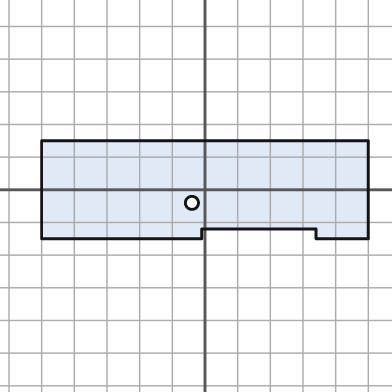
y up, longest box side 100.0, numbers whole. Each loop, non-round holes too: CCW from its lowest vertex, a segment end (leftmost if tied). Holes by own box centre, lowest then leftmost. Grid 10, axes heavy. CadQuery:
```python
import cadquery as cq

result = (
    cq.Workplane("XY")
    .moveTo(-50.0, -15.0)
    .lineTo(-1.0, -15.0)
    .lineTo(-1.0, -12.0)
    .lineTo(34.0, -12.0)
    .lineTo(34.0, -15.0)
    .lineTo(50.0, -15.0)
    .lineTo(50.0, 15.0)
    .lineTo(-50.0, 15.0)
    .close()
    .moveTo(-4.0, -4.0)
    .circle(2.0)
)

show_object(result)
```